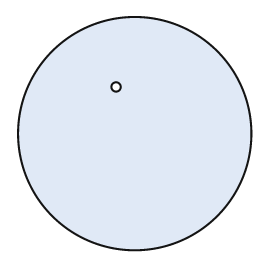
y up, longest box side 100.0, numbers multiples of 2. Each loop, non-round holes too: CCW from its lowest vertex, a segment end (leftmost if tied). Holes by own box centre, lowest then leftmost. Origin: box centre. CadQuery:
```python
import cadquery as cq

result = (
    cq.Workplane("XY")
    .moveTo(0.0, 0.0)
    .circle(50.0)
    .moveTo(-8.0, 20.0)
    .circle(2.0)
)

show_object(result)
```